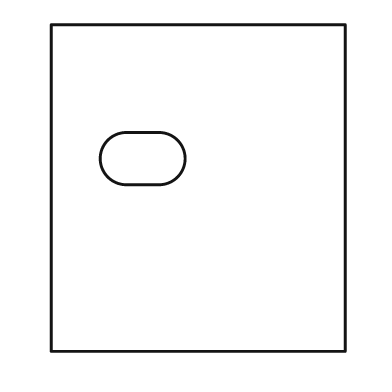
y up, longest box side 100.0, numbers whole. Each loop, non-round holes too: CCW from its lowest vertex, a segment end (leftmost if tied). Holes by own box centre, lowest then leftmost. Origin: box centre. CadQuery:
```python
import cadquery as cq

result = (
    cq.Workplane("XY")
    .moveTo(-45.0, -50.0)
    .lineTo(45.0, -50.0)
    .lineTo(45.0, 50.0)
    .lineTo(-45.0, 50.0)
    .close()
    .moveTo(-22.0, 1.0)
    .lineTo(-12.0, 1.0)
    .threePointArc((-4.0, 9.0), (-12.0, 17.0))
    .lineTo(-22.0, 17.0)
    .threePointArc((-30.0, 9.0), (-22.0, 1.0))
    .close()
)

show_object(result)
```